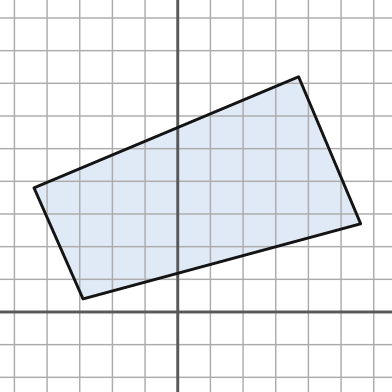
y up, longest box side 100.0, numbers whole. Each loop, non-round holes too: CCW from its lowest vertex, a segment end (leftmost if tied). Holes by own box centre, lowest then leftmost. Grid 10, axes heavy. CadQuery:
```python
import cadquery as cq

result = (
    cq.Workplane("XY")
    .moveTo(-29.0, 4.0)
    .lineTo(56.0, 27.0)
    .lineTo(37.0, 72.0)
    .lineTo(-44.0, 38.0)
    .close()
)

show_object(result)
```